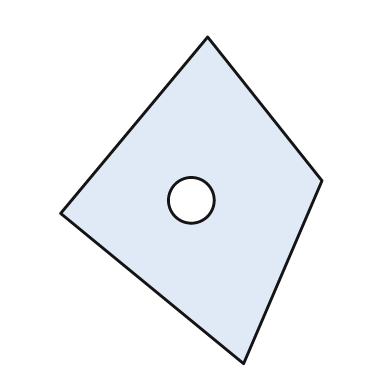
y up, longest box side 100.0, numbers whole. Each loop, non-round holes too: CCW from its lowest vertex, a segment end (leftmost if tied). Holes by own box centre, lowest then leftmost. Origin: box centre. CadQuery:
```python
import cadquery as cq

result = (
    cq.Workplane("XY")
    .moveTo(16.0, -50.0)
    .lineTo(40.0, 6.0)
    .lineTo(5.0, 50.0)
    .lineTo(-40.0, -4.0)
    .close()
    .moveTo(0.0, 0.0)
    .circle(7.0)
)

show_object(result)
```